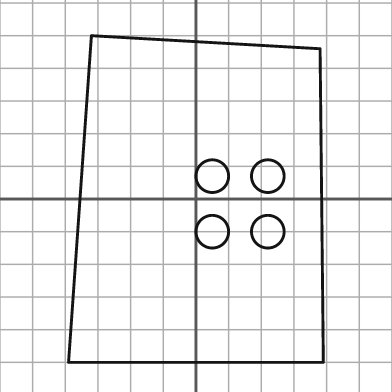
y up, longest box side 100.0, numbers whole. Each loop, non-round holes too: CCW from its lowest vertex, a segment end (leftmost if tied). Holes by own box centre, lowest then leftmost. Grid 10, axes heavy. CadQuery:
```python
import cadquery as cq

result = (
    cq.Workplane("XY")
    .moveTo(-39.0, -50.0)
    .lineTo(39.0, -50.0)
    .lineTo(38.0, 46.0)
    .lineTo(-32.0, 50.0)
    .close()
    .moveTo(5.0, -10.0)
    .circle(5.0)
    .moveTo(22.0, -10.0)
    .circle(5.0)
    .moveTo(5.0, 7.0)
    .circle(5.0)
    .moveTo(22.0, 7.0)
    .circle(5.0)
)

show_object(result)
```